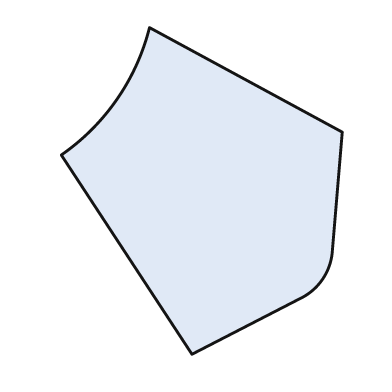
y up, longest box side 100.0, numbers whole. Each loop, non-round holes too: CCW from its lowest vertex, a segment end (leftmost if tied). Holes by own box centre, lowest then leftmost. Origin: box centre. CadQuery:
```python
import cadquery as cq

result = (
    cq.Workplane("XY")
    .moveTo(-3.0, -50.0)
    .lineTo(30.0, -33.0)
    .threePointArc((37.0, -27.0), (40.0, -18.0))
    .lineTo(43.0, 18.0)
    .lineTo(-16.0, 50.0)
    .threePointArc((-26.0, 28.0), (-43.0, 11.0))
    .close()
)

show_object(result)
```